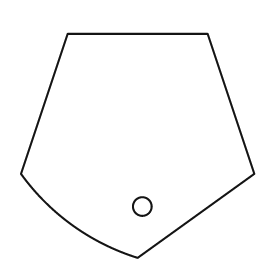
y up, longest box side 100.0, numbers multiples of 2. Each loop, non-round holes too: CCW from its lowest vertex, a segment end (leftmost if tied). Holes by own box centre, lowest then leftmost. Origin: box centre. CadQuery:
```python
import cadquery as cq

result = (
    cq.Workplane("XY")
    .moveTo(0.0, -48.0)
    .lineTo(50.0, -12.0)
    .lineTo(30.0, 48.0)
    .lineTo(-30.0, 48.0)
    .lineTo(-50.0, -12.0)
    .threePointArc((-28.0, -34.0), (0.0, -48.0))
    .close()
    .moveTo(2.0, -26.0)
    .circle(4.0)
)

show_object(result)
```